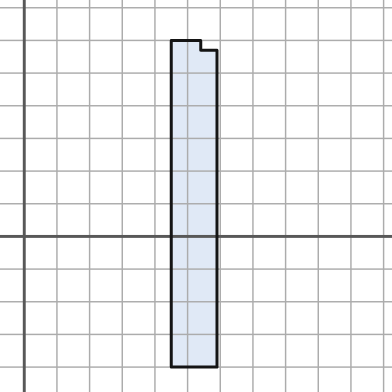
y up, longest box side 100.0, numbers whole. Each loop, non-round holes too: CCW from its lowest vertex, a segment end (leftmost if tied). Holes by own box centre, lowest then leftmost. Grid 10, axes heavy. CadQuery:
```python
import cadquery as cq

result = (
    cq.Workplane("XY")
    .moveTo(45.0, -40.0)
    .lineTo(59.0, -40.0)
    .lineTo(59.0, 57.0)
    .lineTo(54.0, 57.0)
    .lineTo(54.0, 60.0)
    .lineTo(45.0, 60.0)
    .close()
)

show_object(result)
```